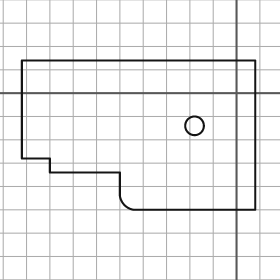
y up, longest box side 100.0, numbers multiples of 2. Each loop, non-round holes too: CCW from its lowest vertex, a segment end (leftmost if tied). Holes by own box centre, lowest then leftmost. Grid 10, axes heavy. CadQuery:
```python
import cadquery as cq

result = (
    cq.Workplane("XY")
    .moveTo(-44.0, -50.0)
    .lineTo(8.0, -50.0)
    .lineTo(8.0, 14.0)
    .lineTo(-92.0, 14.0)
    .lineTo(-92.0, -28.0)
    .lineTo(-80.0, -28.0)
    .lineTo(-80.0, -34.0)
    .lineTo(-50.0, -34.0)
    .lineTo(-50.0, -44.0)
    .threePointArc((-48.0, -48.0), (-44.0, -50.0))
    .close()
    .moveTo(-18.0, -14.0)
    .circle(4.0)
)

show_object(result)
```